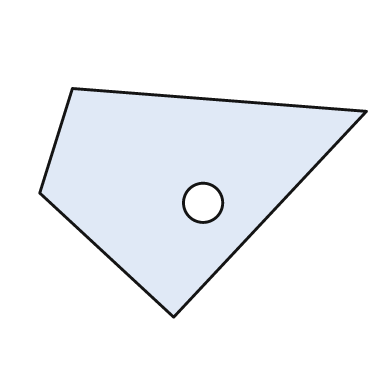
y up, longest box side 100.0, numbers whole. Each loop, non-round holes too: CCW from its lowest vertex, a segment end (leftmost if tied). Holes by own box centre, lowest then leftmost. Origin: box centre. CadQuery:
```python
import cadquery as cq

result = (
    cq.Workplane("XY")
    .moveTo(-9.0, -35.0)
    .lineTo(50.0, 28.0)
    .lineTo(-40.0, 35.0)
    .lineTo(-50.0, 3.0)
    .close()
    .moveTo(0.0, 0.0)
    .circle(6.0)
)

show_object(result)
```